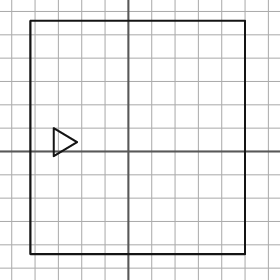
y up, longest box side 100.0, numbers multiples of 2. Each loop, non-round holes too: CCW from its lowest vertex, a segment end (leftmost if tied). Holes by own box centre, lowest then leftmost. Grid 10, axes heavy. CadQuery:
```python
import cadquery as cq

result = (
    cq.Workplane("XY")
    .moveTo(-42.0, -44.0)
    .lineTo(50.0, -44.0)
    .lineTo(50.0, 56.0)
    .lineTo(-42.0, 56.0)
    .close()
    .moveTo(-32.0, -2.0)
    .lineTo(-22.0, 4.0)
    .lineTo(-32.0, 10.0)
    .close()
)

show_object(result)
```